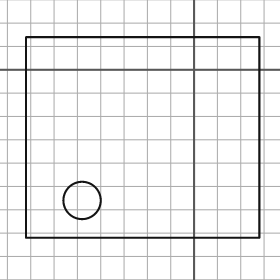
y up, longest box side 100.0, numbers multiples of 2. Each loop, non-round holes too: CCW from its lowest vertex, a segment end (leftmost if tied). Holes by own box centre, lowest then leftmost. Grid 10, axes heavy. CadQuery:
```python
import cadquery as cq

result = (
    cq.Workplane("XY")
    .moveTo(-72.0, -72.0)
    .lineTo(28.0, -72.0)
    .lineTo(28.0, 14.0)
    .lineTo(-72.0, 14.0)
    .close()
    .moveTo(-48.0, -56.0)
    .circle(8.0)
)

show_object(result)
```